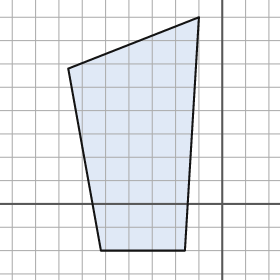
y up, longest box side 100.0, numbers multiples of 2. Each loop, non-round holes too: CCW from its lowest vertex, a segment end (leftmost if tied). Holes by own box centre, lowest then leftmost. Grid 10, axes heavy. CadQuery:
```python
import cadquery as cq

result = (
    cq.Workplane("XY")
    .moveTo(-52.0, -20.0)
    .lineTo(-16.0, -20.0)
    .lineTo(-10.0, 80.0)
    .lineTo(-66.0, 58.0)
    .close()
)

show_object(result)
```